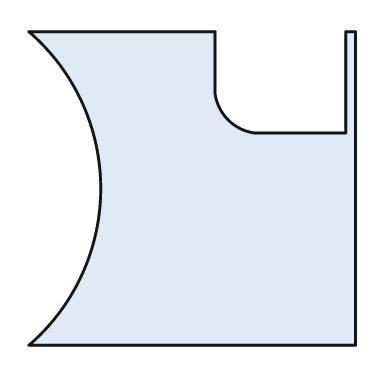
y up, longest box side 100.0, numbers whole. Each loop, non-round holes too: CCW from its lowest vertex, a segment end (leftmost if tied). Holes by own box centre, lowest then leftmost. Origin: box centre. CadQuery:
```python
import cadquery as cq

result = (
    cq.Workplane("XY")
    .moveTo(-50.0, -48.0)
    .lineTo(50.0, -48.0)
    .lineTo(50.0, 48.0)
    .lineTo(47.0, 48.0)
    .lineTo(47.0, 17.0)
    .lineTo(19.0, 17.0)
    .threePointArc((11.0, 21.0), (7.0, 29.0))
    .lineTo(7.0, 48.0)
    .lineTo(-50.0, 48.0)
    .threePointArc((-28.0, 0.0), (-50.0, -48.0))
    .close()
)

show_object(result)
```